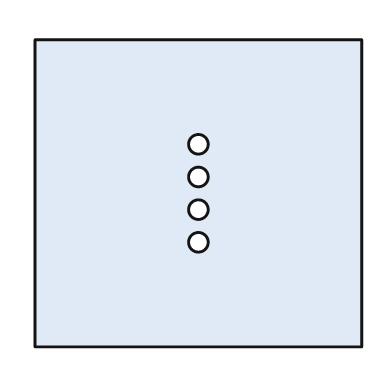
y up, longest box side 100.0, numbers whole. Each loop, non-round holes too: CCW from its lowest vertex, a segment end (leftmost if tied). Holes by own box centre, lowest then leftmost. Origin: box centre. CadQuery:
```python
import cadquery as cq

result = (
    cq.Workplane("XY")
    .moveTo(-50.0, -47.0)
    .lineTo(50.0, -47.0)
    .lineTo(50.0, 47.0)
    .lineTo(-50.0, 47.0)
    .close()
    .moveTo(0.0, -15.0)
    .circle(3.0)
    .moveTo(0.0, -5.0)
    .circle(3.0)
    .moveTo(0.0, 5.0)
    .circle(3.0)
    .moveTo(0.0, 15.0)
    .circle(3.0)
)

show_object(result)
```